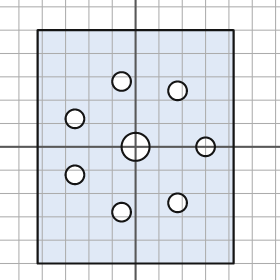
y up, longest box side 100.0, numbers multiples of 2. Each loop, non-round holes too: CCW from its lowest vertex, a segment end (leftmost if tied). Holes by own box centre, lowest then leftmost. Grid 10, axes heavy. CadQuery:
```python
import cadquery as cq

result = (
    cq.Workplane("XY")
    .moveTo(-42.0, -50.0)
    .lineTo(42.0, -50.0)
    .lineTo(42.0, 50.0)
    .lineTo(-42.0, 50.0)
    .close()
    .moveTo(-6.0, -28.0)
    .circle(4.0)
    .moveTo(18.0, -24.0)
    .circle(4.0)
    .moveTo(-26.0, -12.0)
    .circle(4.0)
    .moveTo(0.0, 0.0)
    .circle(6.0)
    .moveTo(30.0, 0.0)
    .circle(4.0)
    .moveTo(-26.0, 12.0)
    .circle(4.0)
    .moveTo(18.0, 24.0)
    .circle(4.0)
    .moveTo(-6.0, 28.0)
    .circle(4.0)
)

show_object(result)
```